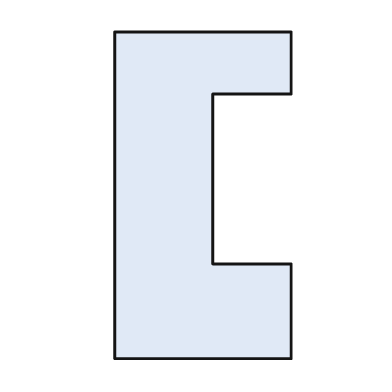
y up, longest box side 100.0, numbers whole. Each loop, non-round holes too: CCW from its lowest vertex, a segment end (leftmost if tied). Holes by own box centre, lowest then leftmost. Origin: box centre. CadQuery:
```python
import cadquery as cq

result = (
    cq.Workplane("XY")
    .moveTo(-27.0, -50.0)
    .lineTo(27.0, -50.0)
    .lineTo(27.0, -21.0)
    .lineTo(3.0, -21.0)
    .lineTo(3.0, 31.0)
    .lineTo(27.0, 31.0)
    .lineTo(27.0, 50.0)
    .lineTo(-27.0, 50.0)
    .close()
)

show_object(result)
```